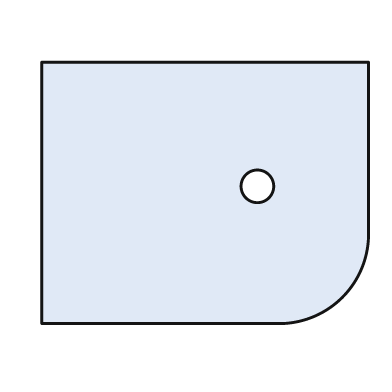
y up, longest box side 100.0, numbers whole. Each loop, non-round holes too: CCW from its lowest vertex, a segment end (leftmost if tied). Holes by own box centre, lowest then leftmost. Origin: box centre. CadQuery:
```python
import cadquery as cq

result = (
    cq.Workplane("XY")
    .moveTo(-50.0, -40.0)
    .lineTo(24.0, -40.0)
    .threePointArc((42.0, -32.0), (50.0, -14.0))
    .lineTo(50.0, 40.0)
    .lineTo(-50.0, 40.0)
    .close()
    .moveTo(16.0, 2.0)
    .circle(5.0)
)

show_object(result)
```